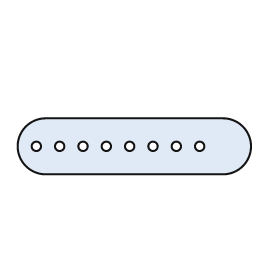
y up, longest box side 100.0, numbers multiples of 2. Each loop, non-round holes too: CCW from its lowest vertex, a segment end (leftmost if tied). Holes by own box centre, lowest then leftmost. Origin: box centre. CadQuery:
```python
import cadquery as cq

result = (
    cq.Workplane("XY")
    .moveTo(-38.0, -12.0)
    .lineTo(38.0, -12.0)
    .threePointArc((50.0, 0.0), (38.0, 12.0))
    .lineTo(-38.0, 12.0)
    .threePointArc((-50.0, 0.0), (-38.0, -12.0))
    .close()
    .moveTo(-42.0, 0.0)
    .circle(2.0)
    .moveTo(-32.0, 0.0)
    .circle(2.0)
    .moveTo(-22.0, 0.0)
    .circle(2.0)
    .moveTo(-12.0, 0.0)
    .circle(2.0)
    .moveTo(-2.0, 0.0)
    .circle(2.0)
    .moveTo(8.0, 0.0)
    .circle(2.0)
    .moveTo(18.0, 0.0)
    .circle(2.0)
    .moveTo(28.0, 0.0)
    .circle(2.0)
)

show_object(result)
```